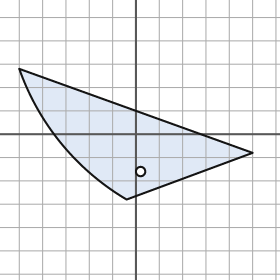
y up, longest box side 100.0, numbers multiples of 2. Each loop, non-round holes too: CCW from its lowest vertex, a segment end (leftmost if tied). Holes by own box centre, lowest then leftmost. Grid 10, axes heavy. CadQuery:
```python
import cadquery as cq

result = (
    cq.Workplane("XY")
    .moveTo(-4.0, -28.0)
    .lineTo(50.0, -8.0)
    .lineTo(-50.0, 28.0)
    .threePointArc((-32.0, -4.0), (-4.0, -28.0))
    .close()
    .moveTo(2.0, -16.0)
    .circle(2.0)
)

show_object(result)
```